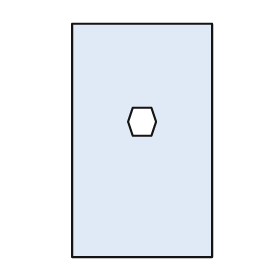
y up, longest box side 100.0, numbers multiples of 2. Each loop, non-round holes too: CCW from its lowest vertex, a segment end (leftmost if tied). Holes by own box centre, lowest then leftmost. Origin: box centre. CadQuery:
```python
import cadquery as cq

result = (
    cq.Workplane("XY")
    .moveTo(-30.0, -50.0)
    .lineTo(30.0, -50.0)
    .lineTo(30.0, 50.0)
    .lineTo(-30.0, 50.0)
    .close()
    .moveTo(-4.0, 2.0)
    .lineTo(4.0, 2.0)
    .lineTo(6.0, 8.0)
    .lineTo(4.0, 14.0)
    .lineTo(-4.0, 14.0)
    .lineTo(-6.0, 8.0)
    .close()
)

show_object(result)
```